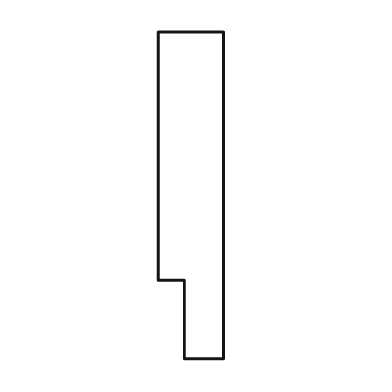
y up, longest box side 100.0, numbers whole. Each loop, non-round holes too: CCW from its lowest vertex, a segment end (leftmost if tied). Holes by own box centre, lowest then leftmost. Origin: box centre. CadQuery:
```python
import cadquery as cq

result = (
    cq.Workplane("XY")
    .moveTo(-2.0, -50.0)
    .lineTo(10.0, -50.0)
    .lineTo(10.0, 50.0)
    .lineTo(-10.0, 50.0)
    .lineTo(-10.0, -26.0)
    .lineTo(-2.0, -26.0)
    .close()
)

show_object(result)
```